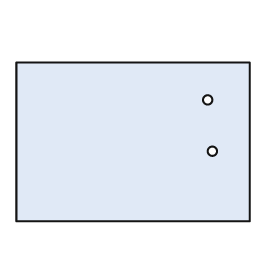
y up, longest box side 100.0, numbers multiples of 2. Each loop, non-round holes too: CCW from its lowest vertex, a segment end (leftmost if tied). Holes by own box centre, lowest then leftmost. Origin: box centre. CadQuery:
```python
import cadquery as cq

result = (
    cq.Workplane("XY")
    .moveTo(-50.0, -34.0)
    .lineTo(50.0, -34.0)
    .lineTo(50.0, 34.0)
    .lineTo(-50.0, 34.0)
    .close()
    .moveTo(34.0, -4.0)
    .circle(2.0)
    .moveTo(32.0, 18.0)
    .circle(2.0)
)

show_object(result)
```